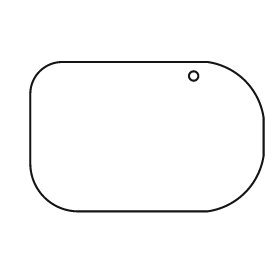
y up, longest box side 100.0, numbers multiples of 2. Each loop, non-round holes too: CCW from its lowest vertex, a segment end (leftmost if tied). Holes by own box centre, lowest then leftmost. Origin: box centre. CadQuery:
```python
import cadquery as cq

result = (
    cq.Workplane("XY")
    .moveTo(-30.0, -32.0)
    .lineTo(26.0, -32.0)
    .threePointArc((42.0, -24.0), (50.0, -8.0))
    .lineTo(50.0, 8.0)
    .threePointArc((42.0, 24.0), (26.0, 32.0))
    .lineTo(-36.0, 32.0)
    .threePointArc((-46.0, 28.0), (-50.0, 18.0))
    .lineTo(-50.0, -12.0)
    .threePointArc((-44.0, -26.0), (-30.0, -32.0))
    .close()
    .moveTo(20.0, 26.0)
    .circle(2.0)
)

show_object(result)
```